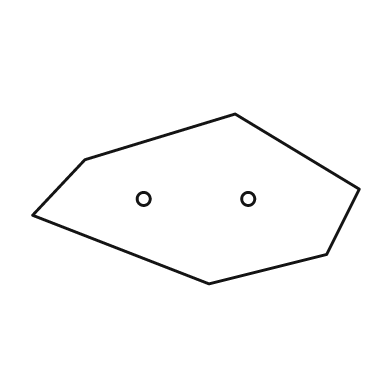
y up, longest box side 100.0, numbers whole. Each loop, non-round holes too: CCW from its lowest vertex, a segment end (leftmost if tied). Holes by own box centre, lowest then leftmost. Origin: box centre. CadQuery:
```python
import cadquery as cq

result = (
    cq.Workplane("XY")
    .moveTo(4.0, -26.0)
    .lineTo(40.0, -17.0)
    .lineTo(50.0, 3.0)
    .lineTo(12.0, 26.0)
    .lineTo(-34.0, 12.0)
    .lineTo(-50.0, -5.0)
    .close()
    .moveTo(-16.0, 0.0)
    .circle(2.0)
    .moveTo(16.0, 0.0)
    .circle(2.0)
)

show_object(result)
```